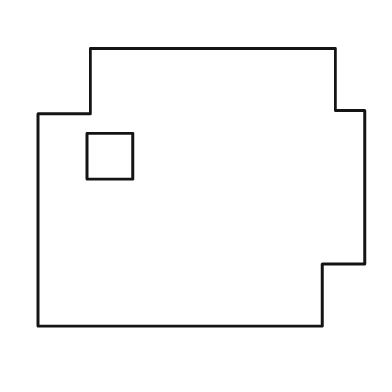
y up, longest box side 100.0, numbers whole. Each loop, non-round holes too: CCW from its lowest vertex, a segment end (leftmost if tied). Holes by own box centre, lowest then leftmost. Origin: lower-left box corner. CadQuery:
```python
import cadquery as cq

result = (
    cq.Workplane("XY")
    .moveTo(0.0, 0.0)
    .lineTo(87.0, 0.0)
    .lineTo(87.0, 19.0)
    .lineTo(100.0, 19.0)
    .lineTo(100.0, 66.0)
    .lineTo(91.0, 66.0)
    .lineTo(91.0, 85.0)
    .lineTo(16.0, 85.0)
    .lineTo(16.0, 65.0)
    .lineTo(0.0, 65.0)
    .close()
    .moveTo(15.0, 45.0)
    .lineTo(29.0, 45.0)
    .lineTo(29.0, 59.0)
    .lineTo(15.0, 59.0)
    .close()
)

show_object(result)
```